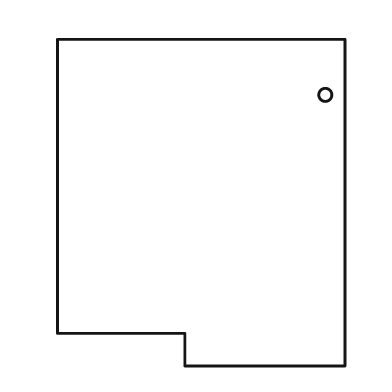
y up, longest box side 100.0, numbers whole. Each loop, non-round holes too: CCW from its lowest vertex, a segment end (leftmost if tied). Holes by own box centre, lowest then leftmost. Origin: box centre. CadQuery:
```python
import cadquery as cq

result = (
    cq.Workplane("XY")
    .moveTo(-5.0, -50.0)
    .lineTo(44.0, -50.0)
    .lineTo(44.0, 50.0)
    .lineTo(-44.0, 50.0)
    .lineTo(-44.0, -40.0)
    .lineTo(-5.0, -40.0)
    .close()
    .moveTo(38.0, 33.0)
    .circle(2.0)
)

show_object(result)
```